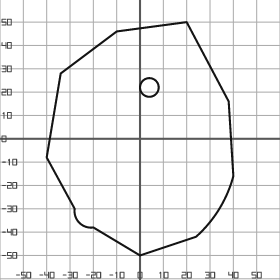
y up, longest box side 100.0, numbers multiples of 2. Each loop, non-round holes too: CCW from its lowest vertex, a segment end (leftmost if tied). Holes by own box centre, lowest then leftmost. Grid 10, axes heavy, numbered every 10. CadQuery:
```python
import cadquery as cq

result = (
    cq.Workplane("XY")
    .moveTo(0.0, -50.0)
    .lineTo(24.0, -42.0)
    .threePointArc((34.0, -30.0), (40.0, -16.0))
    .lineTo(38.0, 16.0)
    .lineTo(20.0, 50.0)
    .lineTo(-10.0, 46.0)
    .lineTo(-34.0, 28.0)
    .lineTo(-40.0, -8.0)
    .lineTo(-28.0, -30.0)
    .threePointArc((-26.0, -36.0), (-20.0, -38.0))
    .close()
    .moveTo(4.0, 22.0)
    .circle(4.0)
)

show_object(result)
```